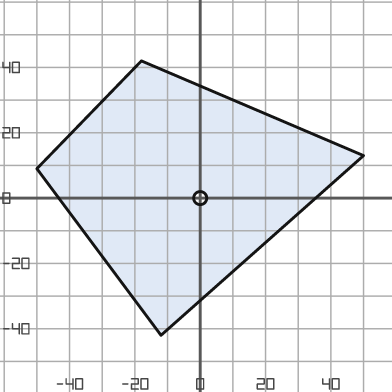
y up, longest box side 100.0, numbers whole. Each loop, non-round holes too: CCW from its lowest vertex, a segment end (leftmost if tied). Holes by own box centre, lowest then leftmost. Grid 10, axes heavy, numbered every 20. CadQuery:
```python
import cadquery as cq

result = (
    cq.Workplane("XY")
    .moveTo(-12.0, -42.0)
    .lineTo(50.0, 13.0)
    .lineTo(-18.0, 42.0)
    .lineTo(-50.0, 9.0)
    .close()
    .moveTo(0.0, 0.0)
    .circle(2.0)
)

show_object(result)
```